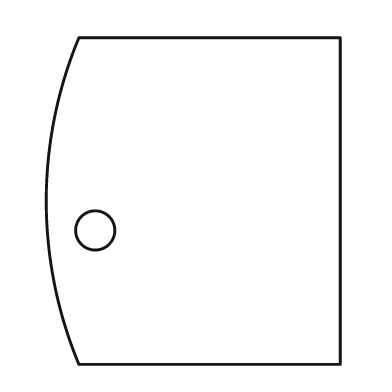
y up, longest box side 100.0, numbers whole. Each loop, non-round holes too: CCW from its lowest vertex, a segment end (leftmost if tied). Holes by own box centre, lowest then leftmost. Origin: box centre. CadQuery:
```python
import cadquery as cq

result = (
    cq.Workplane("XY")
    .moveTo(-35.0, -50.0)
    .lineTo(45.0, -50.0)
    .lineTo(45.0, 50.0)
    .lineTo(-35.0, 50.0)
    .threePointArc((-45.0, 0.0), (-35.0, -50.0))
    .close()
    .moveTo(-30.0, -9.0)
    .circle(6.0)
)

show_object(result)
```